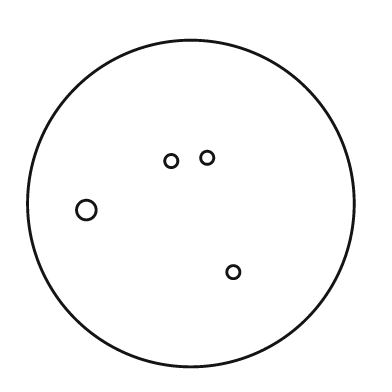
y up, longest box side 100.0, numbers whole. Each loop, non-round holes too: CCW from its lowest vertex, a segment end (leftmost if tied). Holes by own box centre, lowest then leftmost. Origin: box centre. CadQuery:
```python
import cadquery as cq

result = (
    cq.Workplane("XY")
    .moveTo(0.0, 0.0)
    .circle(50.0)
    .moveTo(13.0, -21.0)
    .circle(2.0)
    .moveTo(-32.0, -2.0)
    .circle(3.0)
    .moveTo(-6.0, 13.0)
    .circle(2.0)
    .moveTo(5.0, 14.0)
    .circle(2.0)
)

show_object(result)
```